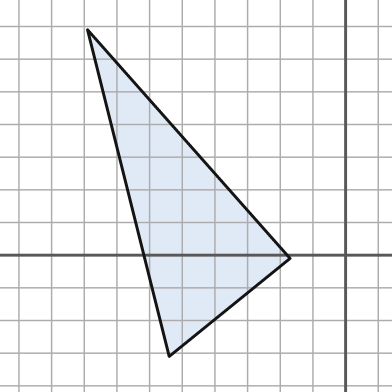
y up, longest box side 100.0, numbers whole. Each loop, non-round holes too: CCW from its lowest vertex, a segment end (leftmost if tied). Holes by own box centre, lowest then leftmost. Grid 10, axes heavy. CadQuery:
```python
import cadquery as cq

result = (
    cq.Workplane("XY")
    .moveTo(-54.0, -31.0)
    .lineTo(-17.0, -1.0)
    .lineTo(-79.0, 69.0)
    .close()
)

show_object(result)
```